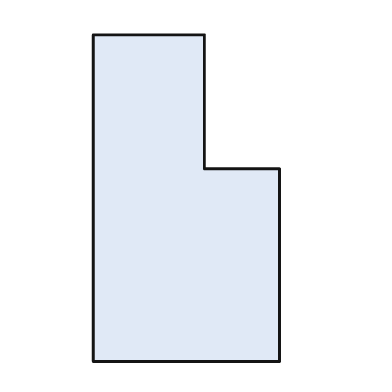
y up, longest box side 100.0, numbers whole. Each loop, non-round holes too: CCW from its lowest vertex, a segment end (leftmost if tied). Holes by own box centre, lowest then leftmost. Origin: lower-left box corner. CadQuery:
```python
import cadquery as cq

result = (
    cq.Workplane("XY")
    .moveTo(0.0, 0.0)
    .lineTo(57.0, 0.0)
    .lineTo(57.0, 59.0)
    .lineTo(34.0, 59.0)
    .lineTo(34.0, 100.0)
    .lineTo(0.0, 100.0)
    .close()
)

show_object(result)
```